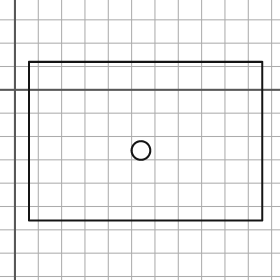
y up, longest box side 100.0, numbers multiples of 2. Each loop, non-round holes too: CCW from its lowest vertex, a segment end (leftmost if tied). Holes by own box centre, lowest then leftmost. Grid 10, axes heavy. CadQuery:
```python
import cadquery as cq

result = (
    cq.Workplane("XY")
    .moveTo(6.0, -56.0)
    .lineTo(106.0, -56.0)
    .lineTo(106.0, 12.0)
    .lineTo(6.0, 12.0)
    .close()
    .moveTo(54.0, -26.0)
    .circle(4.0)
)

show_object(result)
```